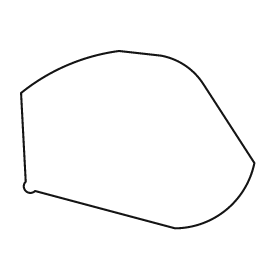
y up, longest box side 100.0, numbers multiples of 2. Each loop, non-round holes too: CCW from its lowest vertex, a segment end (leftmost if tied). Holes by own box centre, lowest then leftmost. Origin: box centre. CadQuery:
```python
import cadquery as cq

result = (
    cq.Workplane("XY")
    .moveTo(16.0, -38.0)
    .threePointArc((38.0, -30.0), (50.0, -10.0))
    .lineTo(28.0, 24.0)
    .threePointArc((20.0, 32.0), (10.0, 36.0))
    .lineTo(-8.0, 38.0)
    .threePointArc((-30.0, 32.0), (-50.0, 20.0))
    .lineTo(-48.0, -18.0)
    .threePointArc((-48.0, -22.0), (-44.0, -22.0))
    .close()
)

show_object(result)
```